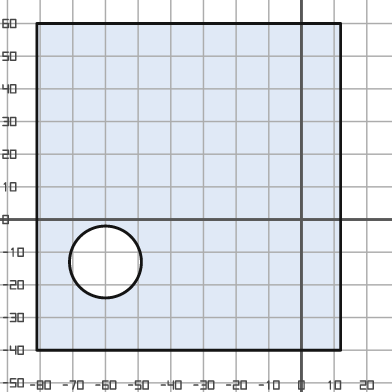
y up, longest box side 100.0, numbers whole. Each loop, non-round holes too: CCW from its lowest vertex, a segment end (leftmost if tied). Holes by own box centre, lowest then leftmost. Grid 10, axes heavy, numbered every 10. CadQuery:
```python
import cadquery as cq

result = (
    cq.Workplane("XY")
    .moveTo(-81.0, -40.0)
    .lineTo(12.0, -40.0)
    .lineTo(12.0, 60.0)
    .lineTo(-81.0, 60.0)
    .close()
    .moveTo(-60.0, -13.0)
    .circle(11.0)
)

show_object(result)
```